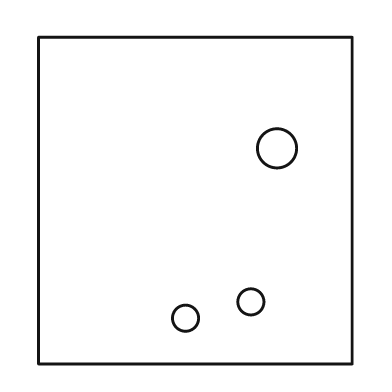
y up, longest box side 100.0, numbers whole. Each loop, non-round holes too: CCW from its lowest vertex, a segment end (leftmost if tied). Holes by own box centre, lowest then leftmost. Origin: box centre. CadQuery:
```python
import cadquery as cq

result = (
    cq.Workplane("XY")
    .moveTo(-48.0, -50.0)
    .lineTo(48.0, -50.0)
    .lineTo(48.0, 50.0)
    .lineTo(-48.0, 50.0)
    .close()
    .moveTo(-3.0, -36.0)
    .circle(4.0)
    .moveTo(17.0, -31.0)
    .circle(4.0)
    .moveTo(25.0, 16.0)
    .circle(6.0)
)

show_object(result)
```